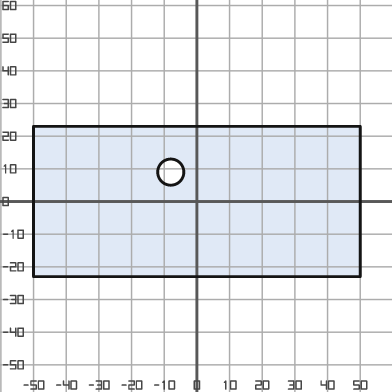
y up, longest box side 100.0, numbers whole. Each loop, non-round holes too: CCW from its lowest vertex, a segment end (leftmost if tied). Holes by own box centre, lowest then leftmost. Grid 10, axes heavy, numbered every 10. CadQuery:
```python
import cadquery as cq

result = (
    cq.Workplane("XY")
    .moveTo(-50.0, -23.0)
    .lineTo(50.0, -23.0)
    .lineTo(50.0, 23.0)
    .lineTo(-50.0, 23.0)
    .close()
    .moveTo(-8.0, 9.0)
    .circle(4.0)
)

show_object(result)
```